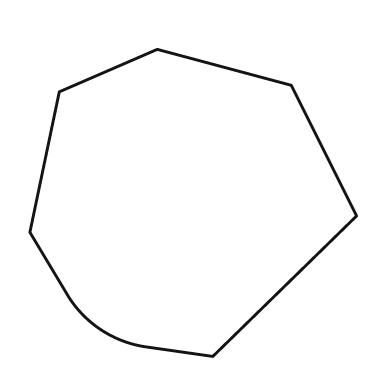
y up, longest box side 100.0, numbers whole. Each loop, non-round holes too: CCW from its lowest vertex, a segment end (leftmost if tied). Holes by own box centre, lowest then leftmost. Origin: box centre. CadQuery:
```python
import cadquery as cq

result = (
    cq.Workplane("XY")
    .moveTo(6.0, -47.0)
    .lineTo(50.0, -4.0)
    .lineTo(30.0, 36.0)
    .lineTo(-11.0, 47.0)
    .lineTo(-41.0, 34.0)
    .lineTo(-50.0, -9.0)
    .lineTo(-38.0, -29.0)
    .threePointArc((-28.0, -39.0), (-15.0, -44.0))
    .close()
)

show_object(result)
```